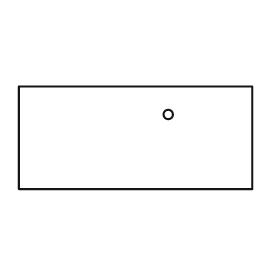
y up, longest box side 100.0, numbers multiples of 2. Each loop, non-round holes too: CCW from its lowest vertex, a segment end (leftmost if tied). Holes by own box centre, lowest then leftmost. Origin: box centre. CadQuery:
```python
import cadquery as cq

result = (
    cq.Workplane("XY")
    .moveTo(-50.0, -22.0)
    .lineTo(50.0, -22.0)
    .lineTo(50.0, 22.0)
    .lineTo(-50.0, 22.0)
    .close()
    .moveTo(14.0, 10.0)
    .circle(2.0)
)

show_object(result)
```